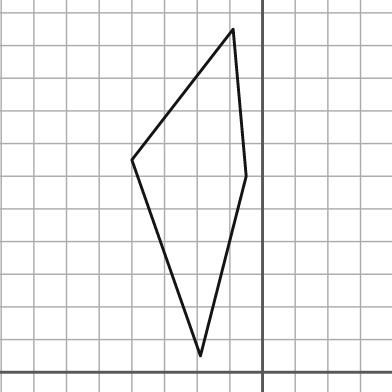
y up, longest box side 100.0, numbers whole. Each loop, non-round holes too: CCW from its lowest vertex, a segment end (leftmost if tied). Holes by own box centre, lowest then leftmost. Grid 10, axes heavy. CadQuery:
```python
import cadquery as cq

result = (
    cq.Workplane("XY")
    .moveTo(-19.0, 5.0)
    .lineTo(-5.0, 60.0)
    .lineTo(-9.0, 105.0)
    .lineTo(-40.0, 65.0)
    .close()
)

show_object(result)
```